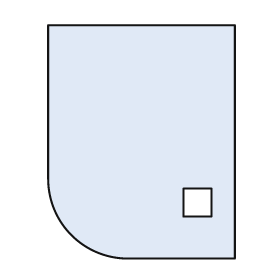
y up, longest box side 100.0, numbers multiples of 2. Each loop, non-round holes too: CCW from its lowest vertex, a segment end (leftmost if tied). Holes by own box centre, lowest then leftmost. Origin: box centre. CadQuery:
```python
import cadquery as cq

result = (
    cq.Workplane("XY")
    .moveTo(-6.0, -50.0)
    .lineTo(40.0, -50.0)
    .lineTo(40.0, 50.0)
    .lineTo(-40.0, 50.0)
    .lineTo(-40.0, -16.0)
    .threePointArc((-30.0, -40.0), (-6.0, -50.0))
    .close()
    .moveTo(18.0, -32.0)
    .lineTo(30.0, -32.0)
    .lineTo(30.0, -20.0)
    .lineTo(18.0, -20.0)
    .close()
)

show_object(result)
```